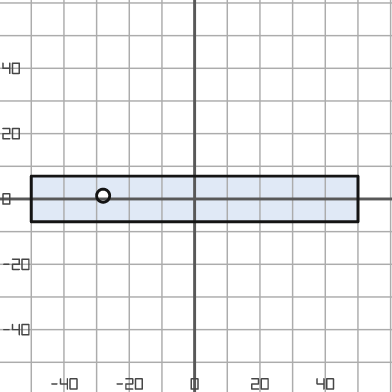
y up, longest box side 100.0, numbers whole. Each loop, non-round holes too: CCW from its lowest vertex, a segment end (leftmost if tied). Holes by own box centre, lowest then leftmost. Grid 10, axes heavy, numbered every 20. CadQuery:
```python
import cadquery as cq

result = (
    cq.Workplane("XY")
    .moveTo(-50.0, -7.0)
    .lineTo(50.0, -7.0)
    .lineTo(50.0, 7.0)
    .lineTo(-50.0, 7.0)
    .close()
    .moveTo(-28.0, 1.0)
    .circle(2.0)
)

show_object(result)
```